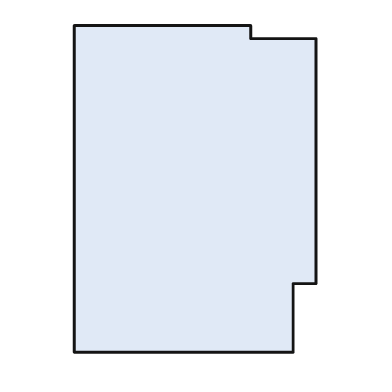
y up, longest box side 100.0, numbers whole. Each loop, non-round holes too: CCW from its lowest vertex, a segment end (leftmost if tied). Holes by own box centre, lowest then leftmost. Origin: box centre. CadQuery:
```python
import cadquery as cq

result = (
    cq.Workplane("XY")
    .moveTo(-37.0, -50.0)
    .lineTo(30.0, -50.0)
    .lineTo(30.0, -29.0)
    .lineTo(37.0, -29.0)
    .lineTo(37.0, 46.0)
    .lineTo(17.0, 46.0)
    .lineTo(17.0, 50.0)
    .lineTo(-37.0, 50.0)
    .close()
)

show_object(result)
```